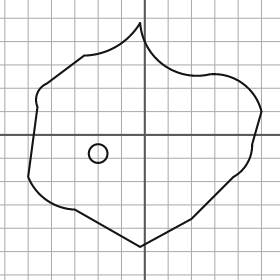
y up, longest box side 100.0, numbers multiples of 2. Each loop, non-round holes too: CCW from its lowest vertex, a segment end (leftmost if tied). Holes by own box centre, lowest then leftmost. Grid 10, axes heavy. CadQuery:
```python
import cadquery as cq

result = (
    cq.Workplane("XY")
    .moveTo(-2.0, -48.0)
    .lineTo(20.0, -36.0)
    .lineTo(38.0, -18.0)
    .threePointArc((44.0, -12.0), (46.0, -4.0))
    .lineTo(50.0, 10.0)
    .threePointArc((42.0, 22.0), (28.0, 26.0))
    .threePointArc((8.0, 30.0), (-2.0, 48.0))
    .threePointArc((-12.0, 38.0), (-26.0, 34.0))
    .lineTo(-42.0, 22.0)
    .threePointArc((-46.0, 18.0), (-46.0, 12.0))
    .lineTo(-50.0, -18.0)
    .threePointArc((-42.0, -28.0), (-30.0, -32.0))
    .close()
    .moveTo(-20.0, -8.0)
    .circle(4.0)
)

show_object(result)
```